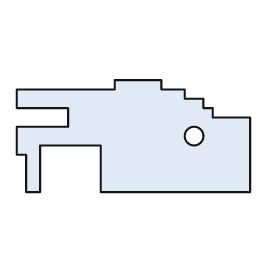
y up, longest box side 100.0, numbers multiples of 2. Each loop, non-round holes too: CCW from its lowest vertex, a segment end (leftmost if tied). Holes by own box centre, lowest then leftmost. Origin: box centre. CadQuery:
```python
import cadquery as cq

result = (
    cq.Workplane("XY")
    .moveTo(-46.0, -24.0)
    .lineTo(-40.0, -24.0)
    .lineTo(-40.0, -4.0)
    .lineTo(-14.0, -4.0)
    .lineTo(-14.0, -24.0)
    .lineTo(50.0, -24.0)
    .lineTo(50.0, 8.0)
    .lineTo(34.0, 8.0)
    .lineTo(34.0, 12.0)
    .lineTo(30.0, 12.0)
    .lineTo(30.0, 16.0)
    .lineTo(22.0, 16.0)
    .lineTo(22.0, 20.0)
    .lineTo(12.0, 20.0)
    .lineTo(12.0, 24.0)
    .lineTo(-8.0, 24.0)
    .lineTo(-8.0, 20.0)
    .lineTo(-50.0, 20.0)
    .lineTo(-50.0, 12.0)
    .lineTo(-28.0, 12.0)
    .lineTo(-28.0, 4.0)
    .lineTo(-50.0, 4.0)
    .lineTo(-50.0, -8.0)
    .lineTo(-46.0, -8.0)
    .close()
    .moveTo(26.0, 0.0)
    .circle(4.0)
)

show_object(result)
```